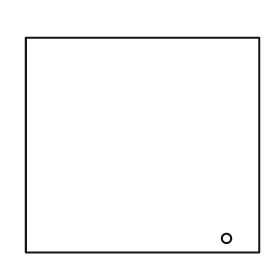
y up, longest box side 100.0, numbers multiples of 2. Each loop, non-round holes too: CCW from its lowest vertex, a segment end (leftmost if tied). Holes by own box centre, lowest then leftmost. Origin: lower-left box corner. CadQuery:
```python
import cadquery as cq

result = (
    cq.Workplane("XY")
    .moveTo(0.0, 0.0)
    .lineTo(100.0, 0.0)
    .lineTo(100.0, 92.0)
    .lineTo(0.0, 92.0)
    .close()
    .moveTo(86.0, 6.0)
    .circle(2.0)
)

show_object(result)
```